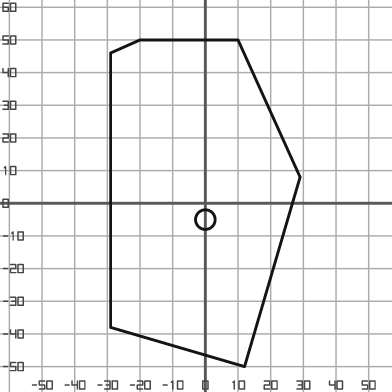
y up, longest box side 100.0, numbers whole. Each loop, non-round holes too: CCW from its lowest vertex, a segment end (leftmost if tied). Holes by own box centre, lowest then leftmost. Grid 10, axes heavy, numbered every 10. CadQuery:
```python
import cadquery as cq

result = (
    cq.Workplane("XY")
    .moveTo(12.0, -50.0)
    .lineTo(29.0, 8.0)
    .lineTo(10.0, 50.0)
    .lineTo(-20.0, 50.0)
    .lineTo(-29.0, 46.0)
    .lineTo(-29.0, -38.0)
    .close()
    .moveTo(0.0, -5.0)
    .circle(3.0)
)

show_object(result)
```